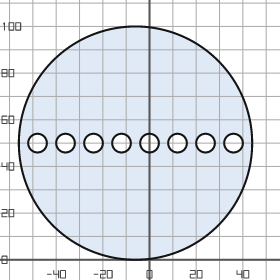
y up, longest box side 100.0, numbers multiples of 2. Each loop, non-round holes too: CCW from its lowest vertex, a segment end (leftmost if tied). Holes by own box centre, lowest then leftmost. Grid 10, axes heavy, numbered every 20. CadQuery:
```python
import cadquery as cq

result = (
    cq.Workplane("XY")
    .moveTo(-6.0, 50.0)
    .circle(50.0)
    .moveTo(-48.0, 50.0)
    .circle(4.0)
    .moveTo(-36.0, 50.0)
    .circle(4.0)
    .moveTo(-24.0, 50.0)
    .circle(4.0)
    .moveTo(-12.0, 50.0)
    .circle(4.0)
    .moveTo(0.0, 50.0)
    .circle(4.0)
    .moveTo(12.0, 50.0)
    .circle(4.0)
    .moveTo(24.0, 50.0)
    .circle(4.0)
    .moveTo(36.0, 50.0)
    .circle(4.0)
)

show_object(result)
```